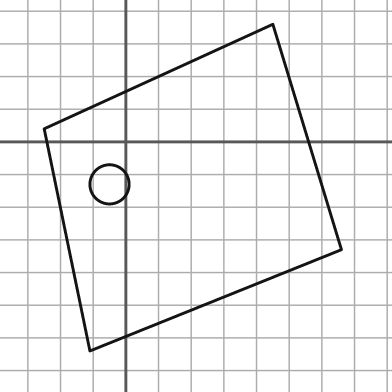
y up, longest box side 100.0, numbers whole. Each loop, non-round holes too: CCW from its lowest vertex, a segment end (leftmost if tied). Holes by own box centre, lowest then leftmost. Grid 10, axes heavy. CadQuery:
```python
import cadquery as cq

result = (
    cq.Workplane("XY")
    .moveTo(-11.0, -64.0)
    .lineTo(66.0, -33.0)
    .lineTo(45.0, 36.0)
    .lineTo(-25.0, 4.0)
    .close()
    .moveTo(-5.0, -13.0)
    .circle(6.0)
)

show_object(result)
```